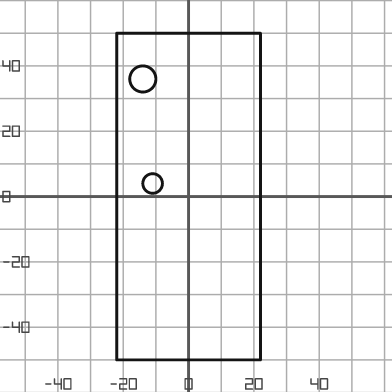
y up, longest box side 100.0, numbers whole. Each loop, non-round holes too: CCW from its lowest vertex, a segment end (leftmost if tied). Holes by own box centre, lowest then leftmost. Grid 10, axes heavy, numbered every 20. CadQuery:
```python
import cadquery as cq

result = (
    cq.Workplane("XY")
    .moveTo(-22.0, -50.0)
    .lineTo(22.0, -50.0)
    .lineTo(22.0, 50.0)
    .lineTo(-22.0, 50.0)
    .close()
    .moveTo(-11.0, 4.0)
    .circle(3.0)
    .moveTo(-14.0, 36.0)
    .circle(4.0)
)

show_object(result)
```